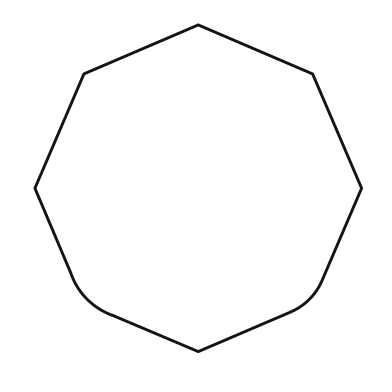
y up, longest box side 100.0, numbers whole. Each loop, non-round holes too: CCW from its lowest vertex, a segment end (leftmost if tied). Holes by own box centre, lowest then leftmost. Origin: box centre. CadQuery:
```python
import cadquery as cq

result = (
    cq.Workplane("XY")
    .moveTo(0.0, -50.0)
    .lineTo(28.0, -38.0)
    .threePointArc((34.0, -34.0), (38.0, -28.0))
    .lineTo(50.0, 0.0)
    .lineTo(35.0, 35.0)
    .lineTo(0.0, 50.0)
    .lineTo(-35.0, 35.0)
    .lineTo(-50.0, 0.0)
    .lineTo(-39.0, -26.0)
    .threePointArc((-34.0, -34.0), (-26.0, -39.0))
    .close()
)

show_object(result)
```